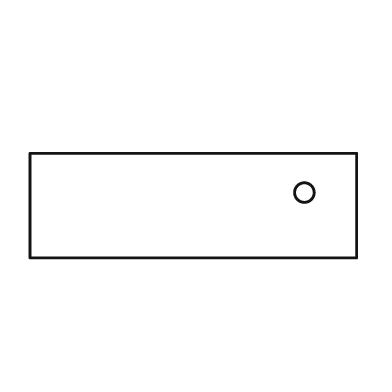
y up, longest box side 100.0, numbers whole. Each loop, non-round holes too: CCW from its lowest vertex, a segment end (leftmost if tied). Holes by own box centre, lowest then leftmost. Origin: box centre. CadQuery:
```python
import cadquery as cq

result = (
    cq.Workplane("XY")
    .moveTo(-50.0, -16.0)
    .lineTo(50.0, -16.0)
    .lineTo(50.0, 16.0)
    .lineTo(-50.0, 16.0)
    .close()
    .moveTo(34.0, 4.0)
    .circle(3.0)
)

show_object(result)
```